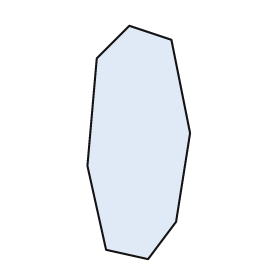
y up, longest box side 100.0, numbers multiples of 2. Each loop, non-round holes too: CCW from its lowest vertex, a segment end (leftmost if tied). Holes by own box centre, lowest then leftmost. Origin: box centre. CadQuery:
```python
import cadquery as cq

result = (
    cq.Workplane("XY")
    .moveTo(4.0, -50.0)
    .lineTo(16.0, -34.0)
    .lineTo(22.0, 4.0)
    .lineTo(14.0, 44.0)
    .lineTo(-4.0, 50.0)
    .lineTo(-18.0, 36.0)
    .lineTo(-22.0, -10.0)
    .lineTo(-14.0, -46.0)
    .close()
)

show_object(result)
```